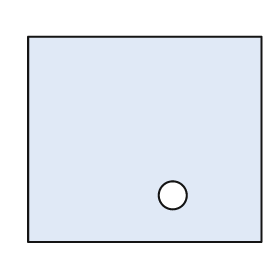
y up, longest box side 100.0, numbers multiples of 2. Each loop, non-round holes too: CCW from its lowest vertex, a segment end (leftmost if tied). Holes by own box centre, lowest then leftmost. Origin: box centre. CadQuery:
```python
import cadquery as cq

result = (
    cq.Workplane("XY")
    .moveTo(-50.0, -44.0)
    .lineTo(50.0, -44.0)
    .lineTo(50.0, 44.0)
    .lineTo(-50.0, 44.0)
    .close()
    .moveTo(12.0, -24.0)
    .circle(6.0)
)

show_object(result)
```